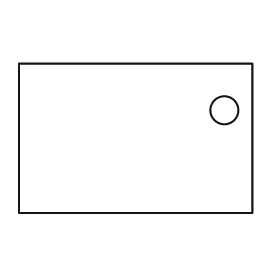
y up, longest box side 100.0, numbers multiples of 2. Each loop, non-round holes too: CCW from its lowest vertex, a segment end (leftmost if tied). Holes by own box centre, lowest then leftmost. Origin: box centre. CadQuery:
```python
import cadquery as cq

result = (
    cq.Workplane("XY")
    .moveTo(-50.0, -32.0)
    .lineTo(50.0, -32.0)
    .lineTo(50.0, 32.0)
    .lineTo(-50.0, 32.0)
    .close()
    .moveTo(38.0, 12.0)
    .circle(6.0)
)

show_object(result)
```